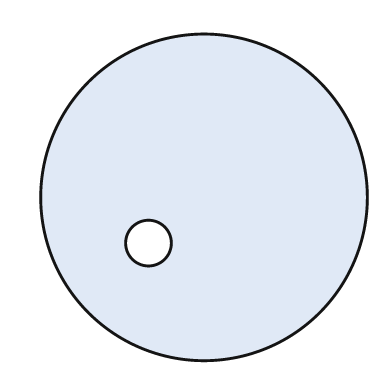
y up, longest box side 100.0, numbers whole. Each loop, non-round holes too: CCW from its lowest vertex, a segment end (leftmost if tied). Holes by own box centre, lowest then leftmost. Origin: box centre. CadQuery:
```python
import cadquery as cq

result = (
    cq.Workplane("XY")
    .moveTo(0.0, 0.0)
    .circle(50.0)
    .moveTo(-17.0, -14.0)
    .circle(7.0)
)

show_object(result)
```